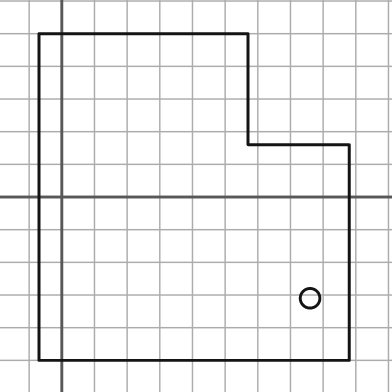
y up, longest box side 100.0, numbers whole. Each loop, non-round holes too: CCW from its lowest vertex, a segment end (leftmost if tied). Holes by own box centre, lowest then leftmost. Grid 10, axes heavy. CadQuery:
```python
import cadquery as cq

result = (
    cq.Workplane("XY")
    .moveTo(-7.0, -50.0)
    .lineTo(88.0, -50.0)
    .lineTo(88.0, 16.0)
    .lineTo(57.0, 16.0)
    .lineTo(57.0, 50.0)
    .lineTo(-7.0, 50.0)
    .close()
    .moveTo(76.0, -31.0)
    .circle(3.0)
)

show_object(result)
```